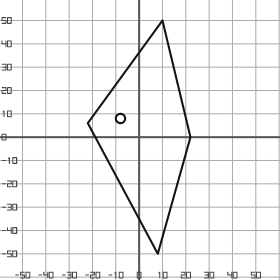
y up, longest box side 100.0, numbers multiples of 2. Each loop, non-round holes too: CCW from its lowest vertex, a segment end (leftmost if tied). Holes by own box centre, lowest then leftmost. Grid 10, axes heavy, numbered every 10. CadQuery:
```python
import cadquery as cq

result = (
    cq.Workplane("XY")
    .moveTo(8.0, -50.0)
    .lineTo(22.0, 0.0)
    .lineTo(10.0, 50.0)
    .lineTo(-22.0, 6.0)
    .close()
    .moveTo(-8.0, 8.0)
    .circle(2.0)
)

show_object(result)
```